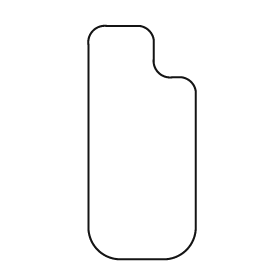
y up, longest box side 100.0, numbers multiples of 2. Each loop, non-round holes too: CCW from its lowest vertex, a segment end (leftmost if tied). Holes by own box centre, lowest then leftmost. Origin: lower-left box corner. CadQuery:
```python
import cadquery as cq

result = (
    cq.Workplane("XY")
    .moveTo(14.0, 0.0)
    .lineTo(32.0, 0.0)
    .threePointArc((42.0, 4.0), (46.0, 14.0))
    .lineTo(46.0, 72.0)
    .threePointArc((44.0, 76.0), (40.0, 78.0))
    .lineTo(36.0, 78.0)
    .threePointArc((30.0, 80.0), (28.0, 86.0))
    .lineTo(28.0, 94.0)
    .threePointArc((26.0, 98.0), (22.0, 100.0))
    .lineTo(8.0, 100.0)
    .threePointArc((2.0, 98.0), (0.0, 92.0))
    .lineTo(0.0, 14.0)
    .threePointArc((4.0, 4.0), (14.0, 0.0))
    .close()
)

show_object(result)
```